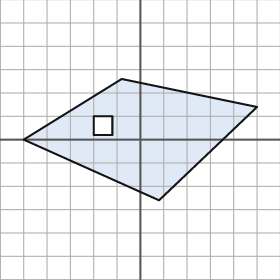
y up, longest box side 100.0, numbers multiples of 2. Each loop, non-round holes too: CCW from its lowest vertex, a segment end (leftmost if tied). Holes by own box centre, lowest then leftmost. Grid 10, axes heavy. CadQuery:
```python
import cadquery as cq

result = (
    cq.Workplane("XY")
    .moveTo(8.0, -26.0)
    .lineTo(50.0, 14.0)
    .lineTo(-8.0, 26.0)
    .lineTo(-50.0, 0.0)
    .close()
    .moveTo(-20.0, 2.0)
    .lineTo(-12.0, 2.0)
    .lineTo(-12.0, 10.0)
    .lineTo(-20.0, 10.0)
    .close()
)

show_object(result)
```